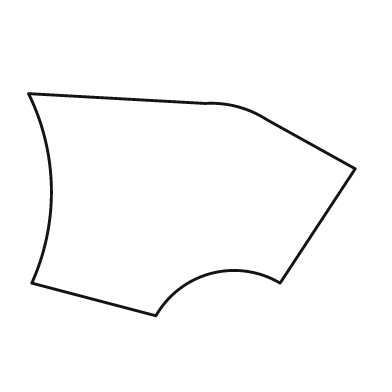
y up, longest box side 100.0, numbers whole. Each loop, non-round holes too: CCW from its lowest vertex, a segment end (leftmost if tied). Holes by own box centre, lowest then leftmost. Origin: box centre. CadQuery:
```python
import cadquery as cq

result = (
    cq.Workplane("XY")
    .moveTo(-11.0, -34.0)
    .threePointArc((6.0, -21.0), (27.0, -24.0))
    .lineTo(50.0, 11.0)
    .lineTo(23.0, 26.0)
    .threePointArc((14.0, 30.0), (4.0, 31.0))
    .lineTo(-50.0, 34.0)
    .threePointArc((-43.0, 5.0), (-49.0, -24.0))
    .close()
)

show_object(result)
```